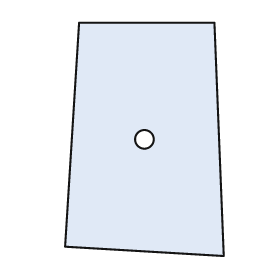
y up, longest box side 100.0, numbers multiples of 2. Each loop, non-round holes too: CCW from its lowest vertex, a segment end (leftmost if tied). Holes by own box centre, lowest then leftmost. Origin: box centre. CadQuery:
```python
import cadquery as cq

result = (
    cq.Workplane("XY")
    .moveTo(34.0, -50.0)
    .lineTo(30.0, 50.0)
    .lineTo(-28.0, 50.0)
    .lineTo(-34.0, -46.0)
    .close()
    .moveTo(0.0, 0.0)
    .circle(4.0)
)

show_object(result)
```